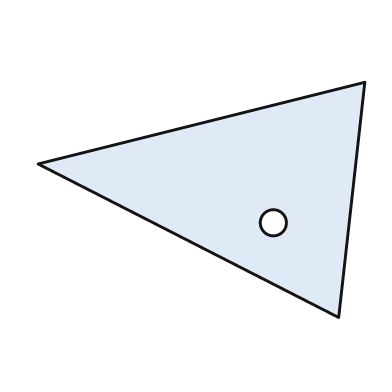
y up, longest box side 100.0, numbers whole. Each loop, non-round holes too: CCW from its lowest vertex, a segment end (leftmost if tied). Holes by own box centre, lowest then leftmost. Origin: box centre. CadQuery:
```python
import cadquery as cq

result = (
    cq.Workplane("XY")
    .moveTo(42.0, -36.0)
    .lineTo(50.0, 36.0)
    .lineTo(-50.0, 11.0)
    .close()
    .moveTo(22.0, -7.0)
    .circle(4.0)
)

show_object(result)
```